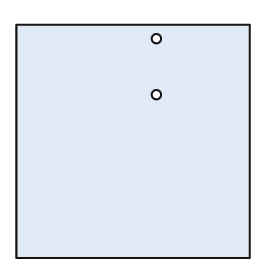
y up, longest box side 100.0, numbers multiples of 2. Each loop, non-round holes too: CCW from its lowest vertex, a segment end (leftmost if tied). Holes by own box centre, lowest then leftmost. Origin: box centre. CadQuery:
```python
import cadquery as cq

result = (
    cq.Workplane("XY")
    .moveTo(-50.0, -50.0)
    .lineTo(50.0, -50.0)
    .lineTo(50.0, 50.0)
    .lineTo(-50.0, 50.0)
    .close()
    .moveTo(10.0, 20.0)
    .circle(2.0)
    .moveTo(10.0, 44.0)
    .circle(2.0)
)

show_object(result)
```